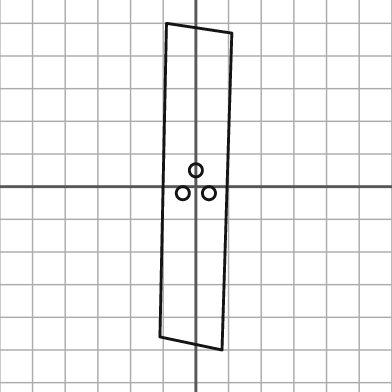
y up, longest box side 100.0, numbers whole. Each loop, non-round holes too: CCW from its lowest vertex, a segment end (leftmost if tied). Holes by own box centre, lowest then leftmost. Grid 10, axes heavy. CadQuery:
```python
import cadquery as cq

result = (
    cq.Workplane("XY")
    .moveTo(8.0, -50.0)
    .lineTo(11.0, 47.0)
    .lineTo(-9.0, 50.0)
    .lineTo(-11.0, -46.0)
    .close()
    .moveTo(-4.0, -2.0)
    .circle(2.0)
    .moveTo(4.0, -2.0)
    .circle(2.0)
    .moveTo(0.0, 5.0)
    .circle(2.0)
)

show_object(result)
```